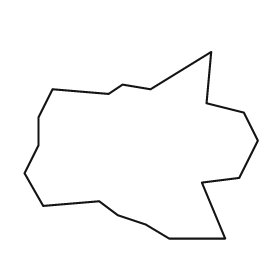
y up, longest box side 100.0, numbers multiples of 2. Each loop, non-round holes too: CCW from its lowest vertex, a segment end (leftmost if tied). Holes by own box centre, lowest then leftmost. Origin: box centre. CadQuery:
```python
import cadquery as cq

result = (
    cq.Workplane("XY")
    .moveTo(12.0, -40.0)
    .lineTo(36.0, -40.0)
    .lineTo(26.0, -16.0)
    .lineTo(42.0, -14.0)
    .lineTo(50.0, 2.0)
    .lineTo(44.0, 14.0)
    .lineTo(28.0, 18.0)
    .lineTo(30.0, 40.0)
    .lineTo(4.0, 24.0)
    .lineTo(-8.0, 26.0)
    .lineTo(-14.0, 22.0)
    .lineTo(-38.0, 24.0)
    .lineTo(-44.0, 12.0)
    .lineTo(-44.0, 0.0)
    .lineTo(-50.0, -12.0)
    .lineTo(-42.0, -26.0)
    .lineTo(-18.0, -24.0)
    .lineTo(-10.0, -30.0)
    .lineTo(2.0, -34.0)
    .close()
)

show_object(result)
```